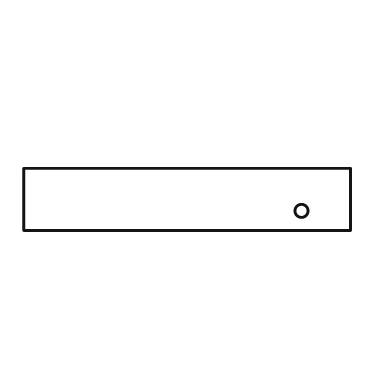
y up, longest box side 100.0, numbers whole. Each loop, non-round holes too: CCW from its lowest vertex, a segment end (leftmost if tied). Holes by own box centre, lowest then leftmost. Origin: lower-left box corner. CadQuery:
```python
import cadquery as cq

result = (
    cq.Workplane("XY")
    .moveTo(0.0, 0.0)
    .lineTo(100.0, 0.0)
    .lineTo(100.0, 19.0)
    .lineTo(0.0, 19.0)
    .close()
    .moveTo(85.0, 6.0)
    .circle(2.0)
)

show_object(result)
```